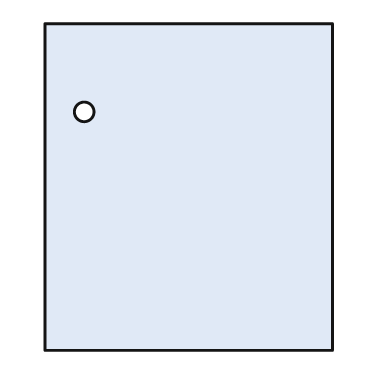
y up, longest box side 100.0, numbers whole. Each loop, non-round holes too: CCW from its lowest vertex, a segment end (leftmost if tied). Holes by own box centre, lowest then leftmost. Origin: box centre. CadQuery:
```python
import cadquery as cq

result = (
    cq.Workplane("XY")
    .moveTo(-44.0, -50.0)
    .lineTo(44.0, -50.0)
    .lineTo(44.0, 50.0)
    .lineTo(-44.0, 50.0)
    .close()
    .moveTo(-32.0, 23.0)
    .circle(3.0)
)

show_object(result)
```